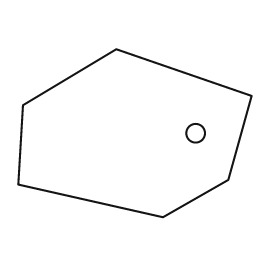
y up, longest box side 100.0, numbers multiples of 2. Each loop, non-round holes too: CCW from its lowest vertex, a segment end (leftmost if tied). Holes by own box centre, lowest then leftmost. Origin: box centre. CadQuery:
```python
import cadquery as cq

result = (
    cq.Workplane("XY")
    .moveTo(12.0, -36.0)
    .lineTo(40.0, -20.0)
    .lineTo(50.0, 16.0)
    .lineTo(-8.0, 36.0)
    .lineTo(-48.0, 12.0)
    .lineTo(-50.0, -22.0)
    .close()
    .moveTo(26.0, 0.0)
    .circle(4.0)
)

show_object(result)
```